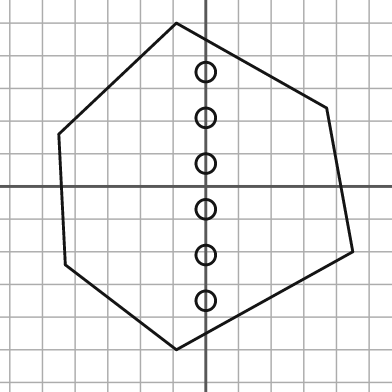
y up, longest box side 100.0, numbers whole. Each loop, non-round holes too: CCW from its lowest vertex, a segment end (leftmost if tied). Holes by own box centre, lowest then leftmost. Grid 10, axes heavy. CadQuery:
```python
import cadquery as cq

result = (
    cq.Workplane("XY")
    .moveTo(-9.0, -50.0)
    .lineTo(45.0, -20.0)
    .lineTo(37.0, 24.0)
    .lineTo(-9.0, 50.0)
    .lineTo(-45.0, 16.0)
    .lineTo(-43.0, -24.0)
    .close()
    .moveTo(0.0, -35.0)
    .circle(3.0)
    .moveTo(0.0, -21.0)
    .circle(3.0)
    .moveTo(0.0, -7.0)
    .circle(3.0)
    .moveTo(0.0, 7.0)
    .circle(3.0)
    .moveTo(0.0, 21.0)
    .circle(3.0)
    .moveTo(0.0, 35.0)
    .circle(3.0)
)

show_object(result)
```